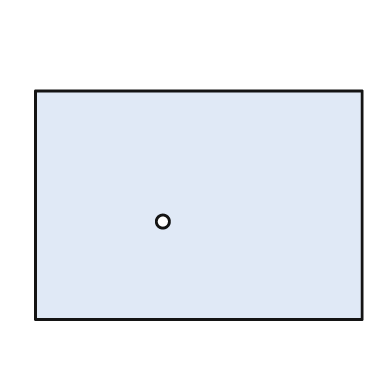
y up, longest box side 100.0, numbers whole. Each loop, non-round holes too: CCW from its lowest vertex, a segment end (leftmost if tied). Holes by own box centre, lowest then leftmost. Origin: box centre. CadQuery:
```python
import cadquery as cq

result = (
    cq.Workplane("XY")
    .moveTo(-50.0, -35.0)
    .lineTo(50.0, -35.0)
    .lineTo(50.0, 35.0)
    .lineTo(-50.0, 35.0)
    .close()
    .moveTo(-11.0, -5.0)
    .circle(2.0)
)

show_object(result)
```